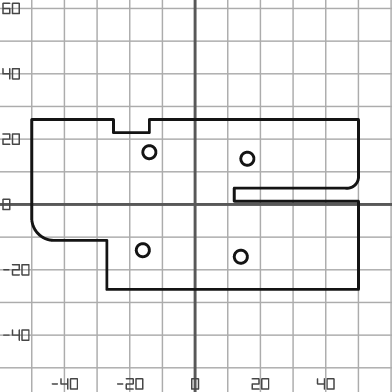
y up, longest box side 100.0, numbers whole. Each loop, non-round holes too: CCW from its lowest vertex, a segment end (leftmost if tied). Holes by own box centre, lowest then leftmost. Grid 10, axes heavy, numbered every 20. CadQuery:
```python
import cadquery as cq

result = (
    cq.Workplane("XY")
    .moveTo(-27.0, -26.0)
    .lineTo(50.0, -26.0)
    .lineTo(50.0, 1.0)
    .lineTo(12.0, 1.0)
    .lineTo(12.0, 5.0)
    .lineTo(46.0, 5.0)
    .threePointArc((49.0, 6.0), (50.0, 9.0))
    .lineTo(50.0, 26.0)
    .lineTo(-14.0, 26.0)
    .lineTo(-14.0, 22.0)
    .lineTo(-25.0, 22.0)
    .lineTo(-25.0, 26.0)
    .lineTo(-50.0, 26.0)
    .lineTo(-50.0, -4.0)
    .threePointArc((-48.0, -9.0), (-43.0, -11.0))
    .lineTo(-27.0, -11.0)
    .close()
    .moveTo(14.0, -16.0)
    .circle(2.0)
    .moveTo(-16.0, -14.0)
    .circle(2.0)
    .moveTo(16.0, 14.0)
    .circle(2.0)
    .moveTo(-14.0, 16.0)
    .circle(2.0)
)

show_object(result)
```